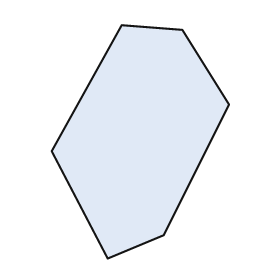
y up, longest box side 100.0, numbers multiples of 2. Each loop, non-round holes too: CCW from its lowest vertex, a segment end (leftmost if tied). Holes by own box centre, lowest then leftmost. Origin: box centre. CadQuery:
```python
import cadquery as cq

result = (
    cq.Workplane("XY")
    .moveTo(-14.0, -50.0)
    .lineTo(10.0, -40.0)
    .lineTo(38.0, 16.0)
    .lineTo(18.0, 48.0)
    .lineTo(-8.0, 50.0)
    .lineTo(-38.0, -4.0)
    .close()
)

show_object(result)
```